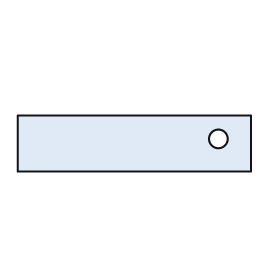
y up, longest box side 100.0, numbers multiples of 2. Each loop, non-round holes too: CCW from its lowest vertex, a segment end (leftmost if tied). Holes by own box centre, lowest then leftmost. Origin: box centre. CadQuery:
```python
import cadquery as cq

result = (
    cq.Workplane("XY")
    .moveTo(-50.0, -12.0)
    .lineTo(50.0, -12.0)
    .lineTo(50.0, 12.0)
    .lineTo(-50.0, 12.0)
    .close()
    .moveTo(36.0, 2.0)
    .circle(4.0)
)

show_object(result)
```